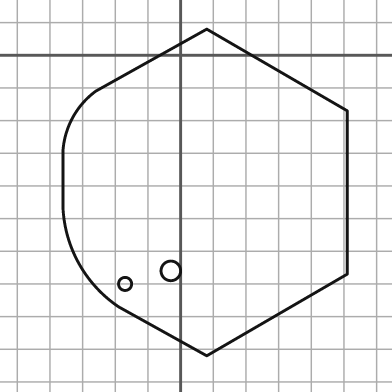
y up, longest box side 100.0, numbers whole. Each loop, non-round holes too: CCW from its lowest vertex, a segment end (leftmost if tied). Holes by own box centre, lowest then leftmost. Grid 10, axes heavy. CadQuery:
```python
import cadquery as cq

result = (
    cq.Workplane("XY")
    .moveTo(8.0, -92.0)
    .lineTo(51.0, -67.0)
    .lineTo(51.0, -17.0)
    .lineTo(8.0, 8.0)
    .lineTo(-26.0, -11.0)
    .threePointArc((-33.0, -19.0), (-36.0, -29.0))
    .lineTo(-36.0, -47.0)
    .threePointArc((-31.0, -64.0), (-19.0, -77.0))
    .close()
    .moveTo(-17.0, -70.0)
    .circle(2.0)
    .moveTo(-3.0, -66.0)
    .circle(3.0)
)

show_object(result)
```